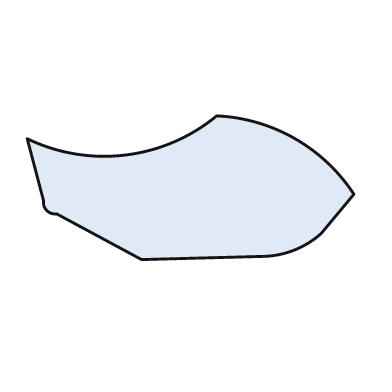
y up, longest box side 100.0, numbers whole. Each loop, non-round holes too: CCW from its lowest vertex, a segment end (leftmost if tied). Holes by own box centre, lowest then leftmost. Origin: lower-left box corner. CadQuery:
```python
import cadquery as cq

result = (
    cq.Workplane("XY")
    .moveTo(35.0, 0.0)
    .lineTo(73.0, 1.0)
    .threePointArc((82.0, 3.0), (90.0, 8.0))
    .lineTo(100.0, 20.0)
    .threePointArc((82.0, 37.0), (58.0, 44.0))
    .threePointArc((30.0, 32.0), (0.0, 37.0))
    .lineTo(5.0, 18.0)
    .threePointArc((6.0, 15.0), (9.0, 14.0))
    .close()
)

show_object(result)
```